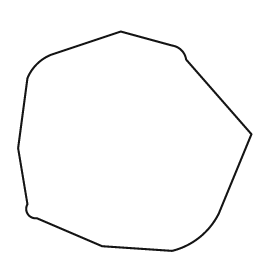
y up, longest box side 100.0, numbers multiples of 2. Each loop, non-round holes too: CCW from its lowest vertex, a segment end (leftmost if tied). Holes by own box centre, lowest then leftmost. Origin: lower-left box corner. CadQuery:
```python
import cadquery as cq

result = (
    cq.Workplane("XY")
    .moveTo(66.0, 0.0)
    .threePointArc((78.0, 6.0), (86.0, 16.0))
    .lineTo(100.0, 50.0)
    .lineTo(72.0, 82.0)
    .threePointArc((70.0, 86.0), (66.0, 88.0))
    .lineTo(44.0, 94.0)
    .lineTo(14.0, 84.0)
    .threePointArc((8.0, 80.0), (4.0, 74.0))
    .lineTo(0.0, 44.0)
    .lineTo(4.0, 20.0)
    .threePointArc((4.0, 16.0), (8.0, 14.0))
    .lineTo(36.0, 2.0)
    .close()
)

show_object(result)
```